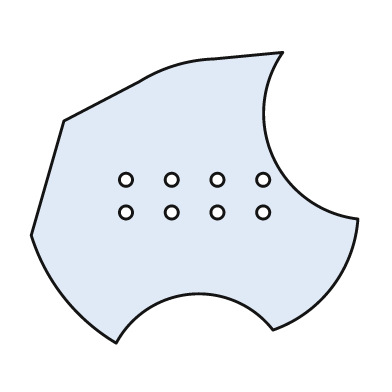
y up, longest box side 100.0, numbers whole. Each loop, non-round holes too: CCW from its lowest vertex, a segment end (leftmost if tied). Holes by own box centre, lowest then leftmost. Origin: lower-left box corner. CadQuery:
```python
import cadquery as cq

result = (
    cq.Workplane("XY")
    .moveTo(26.0, 0.0)
    .threePointArc((49.0, 15.0), (74.0, 4.0))
    .threePointArc((92.0, 17.0), (100.0, 38.0))
    .threePointArc((74.0, 57.0), (77.0, 89.0))
    .lineTo(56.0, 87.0)
    .threePointArc((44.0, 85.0), (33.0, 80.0))
    .lineTo(10.0, 68.0)
    .lineTo(0.0, 33.0)
    .threePointArc((10.0, 14.0), (26.0, 0.0))
    .close()
    .moveTo(29.0, 40.0)
    .circle(2.0)
    .moveTo(43.0, 40.0)
    .circle(2.0)
    .moveTo(57.0, 40.0)
    .circle(2.0)
    .moveTo(71.0, 40.0)
    .circle(2.0)
    .moveTo(29.0, 50.0)
    .circle(2.0)
    .moveTo(43.0, 50.0)
    .circle(2.0)
    .moveTo(57.0, 50.0)
    .circle(2.0)
    .moveTo(71.0, 50.0)
    .circle(2.0)
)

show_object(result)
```